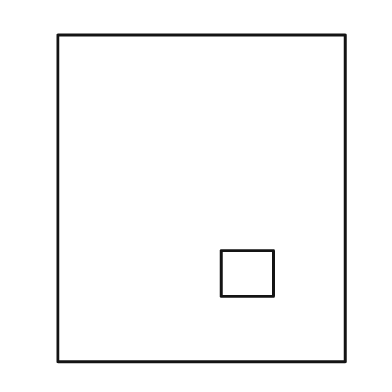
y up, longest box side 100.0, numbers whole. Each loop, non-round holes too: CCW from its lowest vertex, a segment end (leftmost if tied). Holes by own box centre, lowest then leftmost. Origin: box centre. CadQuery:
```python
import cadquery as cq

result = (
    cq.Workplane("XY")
    .moveTo(-44.0, -50.0)
    .lineTo(44.0, -50.0)
    .lineTo(44.0, 50.0)
    .lineTo(-44.0, 50.0)
    .close()
    .moveTo(6.0, -30.0)
    .lineTo(22.0, -30.0)
    .lineTo(22.0, -16.0)
    .lineTo(6.0, -16.0)
    .close()
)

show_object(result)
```